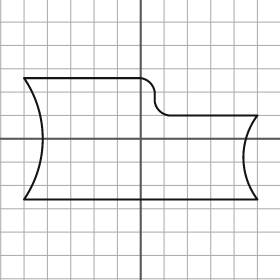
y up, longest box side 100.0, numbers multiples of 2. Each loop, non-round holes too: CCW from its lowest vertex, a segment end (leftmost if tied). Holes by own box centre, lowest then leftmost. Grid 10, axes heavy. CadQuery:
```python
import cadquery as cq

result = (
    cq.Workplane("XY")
    .moveTo(-50.0, -26.0)
    .lineTo(50.0, -26.0)
    .threePointArc((44.0, -8.0), (50.0, 10.0))
    .lineTo(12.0, 10.0)
    .threePointArc((8.0, 12.0), (6.0, 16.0))
    .lineTo(6.0, 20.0)
    .threePointArc((4.0, 24.0), (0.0, 26.0))
    .lineTo(-50.0, 26.0)
    .threePointArc((-42.0, 0.0), (-50.0, -26.0))
    .close()
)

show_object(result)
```